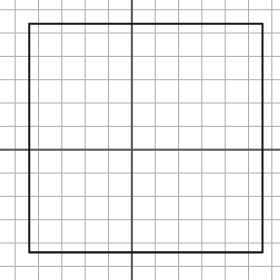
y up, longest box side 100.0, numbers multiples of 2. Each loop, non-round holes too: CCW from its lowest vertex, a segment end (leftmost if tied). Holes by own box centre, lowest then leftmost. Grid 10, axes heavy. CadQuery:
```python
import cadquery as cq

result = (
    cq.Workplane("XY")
    .moveTo(-44.0, -44.0)
    .lineTo(56.0, -44.0)
    .lineTo(56.0, 54.0)
    .lineTo(-44.0, 54.0)
    .close()
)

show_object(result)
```